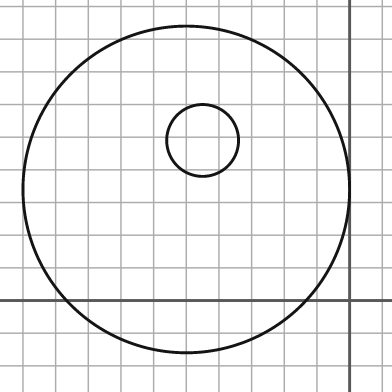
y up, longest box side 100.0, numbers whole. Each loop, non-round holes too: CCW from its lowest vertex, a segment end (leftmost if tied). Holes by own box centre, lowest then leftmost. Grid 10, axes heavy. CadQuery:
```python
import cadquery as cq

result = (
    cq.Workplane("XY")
    .moveTo(-50.0, 34.0)
    .circle(50.0)
    .moveTo(-45.0, 49.0)
    .circle(11.0)
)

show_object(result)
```